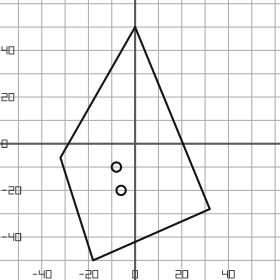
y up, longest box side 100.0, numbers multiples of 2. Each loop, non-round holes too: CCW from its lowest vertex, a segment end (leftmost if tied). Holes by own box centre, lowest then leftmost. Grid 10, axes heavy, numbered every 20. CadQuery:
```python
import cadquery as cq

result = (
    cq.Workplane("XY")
    .moveTo(-18.0, -50.0)
    .lineTo(32.0, -28.0)
    .lineTo(0.0, 50.0)
    .lineTo(-32.0, -6.0)
    .close()
    .moveTo(-6.0, -20.0)
    .circle(2.0)
    .moveTo(-8.0, -10.0)
    .circle(2.0)
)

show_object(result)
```